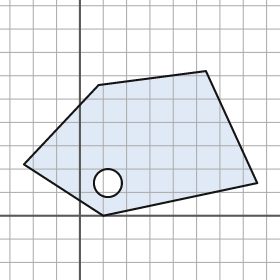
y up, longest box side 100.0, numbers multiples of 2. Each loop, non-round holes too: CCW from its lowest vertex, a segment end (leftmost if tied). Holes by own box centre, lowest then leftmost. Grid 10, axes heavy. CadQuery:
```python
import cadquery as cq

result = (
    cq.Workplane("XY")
    .moveTo(10.0, 0.0)
    .lineTo(76.0, 14.0)
    .lineTo(54.0, 62.0)
    .lineTo(8.0, 56.0)
    .lineTo(-24.0, 22.0)
    .close()
    .moveTo(12.0, 14.0)
    .circle(6.0)
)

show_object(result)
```